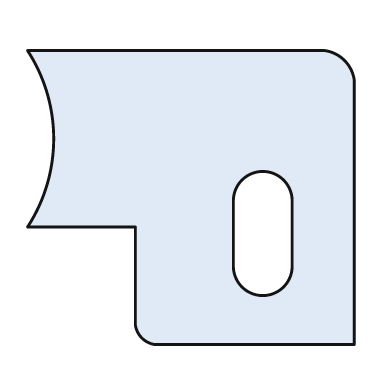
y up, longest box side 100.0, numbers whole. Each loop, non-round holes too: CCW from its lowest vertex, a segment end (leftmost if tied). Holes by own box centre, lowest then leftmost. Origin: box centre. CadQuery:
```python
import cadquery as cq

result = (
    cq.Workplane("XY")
    .moveTo(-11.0, -45.0)
    .lineTo(50.0, -45.0)
    .lineTo(50.0, 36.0)
    .threePointArc((47.0, 42.0), (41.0, 45.0))
    .lineTo(-50.0, 45.0)
    .threePointArc((-42.0, 18.0), (-50.0, -9.0))
    .lineTo(-17.0, -9.0)
    .lineTo(-17.0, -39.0)
    .threePointArc((-15.0, -43.0), (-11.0, -45.0))
    .close()
    .moveTo(13.0, -21.0)
    .threePointArc((22.0, -30.0), (31.0, -21.0))
    .lineTo(31.0, -1.0)
    .threePointArc((22.0, 8.0), (13.0, -1.0))
    .close()
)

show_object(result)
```